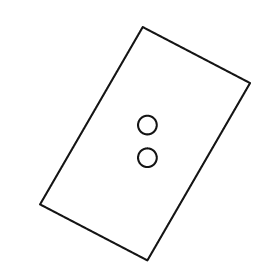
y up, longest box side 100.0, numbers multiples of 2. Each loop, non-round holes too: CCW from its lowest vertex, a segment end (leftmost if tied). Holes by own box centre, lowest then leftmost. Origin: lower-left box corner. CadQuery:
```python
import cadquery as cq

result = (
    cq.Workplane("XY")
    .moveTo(46.0, 0.0)
    .lineTo(90.0, 76.0)
    .lineTo(44.0, 100.0)
    .lineTo(0.0, 24.0)
    .close()
    .moveTo(46.0, 44.0)
    .circle(4.0)
    .moveTo(46.0, 58.0)
    .circle(4.0)
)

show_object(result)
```